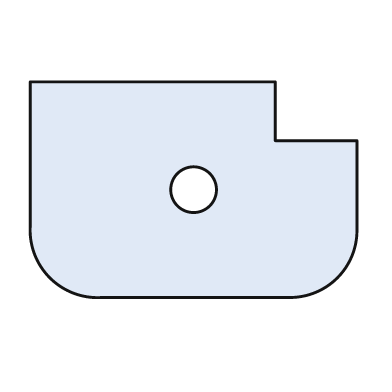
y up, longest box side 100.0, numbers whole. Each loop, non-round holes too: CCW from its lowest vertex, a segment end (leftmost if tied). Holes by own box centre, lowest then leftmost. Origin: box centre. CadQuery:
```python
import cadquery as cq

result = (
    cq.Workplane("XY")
    .moveTo(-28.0, -33.0)
    .lineTo(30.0, -33.0)
    .threePointArc((44.0, -27.0), (50.0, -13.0))
    .lineTo(50.0, 15.0)
    .lineTo(25.0, 15.0)
    .lineTo(25.0, 33.0)
    .lineTo(-50.0, 33.0)
    .lineTo(-50.0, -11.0)
    .threePointArc((-44.0, -27.0), (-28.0, -33.0))
    .close()
    .moveTo(0.0, 0.0)
    .circle(7.0)
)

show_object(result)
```